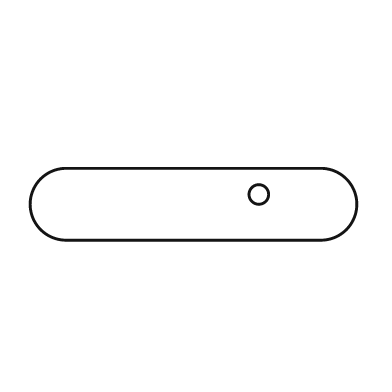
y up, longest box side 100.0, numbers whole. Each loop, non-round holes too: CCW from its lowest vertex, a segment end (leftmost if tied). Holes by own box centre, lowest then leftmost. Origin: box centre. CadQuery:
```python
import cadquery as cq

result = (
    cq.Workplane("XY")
    .moveTo(-39.0, -11.0)
    .lineTo(39.0, -11.0)
    .threePointArc((50.0, 0.0), (39.0, 11.0))
    .lineTo(-39.0, 11.0)
    .threePointArc((-50.0, 0.0), (-39.0, -11.0))
    .close()
    .moveTo(20.0, 3.0)
    .circle(3.0)
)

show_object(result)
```